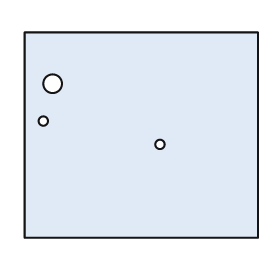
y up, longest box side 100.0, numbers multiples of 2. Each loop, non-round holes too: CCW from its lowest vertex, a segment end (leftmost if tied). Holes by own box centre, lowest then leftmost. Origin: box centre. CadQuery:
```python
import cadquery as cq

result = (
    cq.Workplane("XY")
    .moveTo(-50.0, -44.0)
    .lineTo(50.0, -44.0)
    .lineTo(50.0, 44.0)
    .lineTo(-50.0, 44.0)
    .close()
    .moveTo(8.0, -4.0)
    .circle(2.0)
    .moveTo(-42.0, 6.0)
    .circle(2.0)
    .moveTo(-38.0, 22.0)
    .circle(4.0)
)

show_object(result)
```